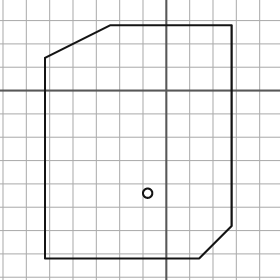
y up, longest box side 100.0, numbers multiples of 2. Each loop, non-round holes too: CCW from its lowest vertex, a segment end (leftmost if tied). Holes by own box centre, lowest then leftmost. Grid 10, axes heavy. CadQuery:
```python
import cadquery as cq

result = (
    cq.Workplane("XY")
    .moveTo(-52.0, -72.0)
    .lineTo(14.0, -72.0)
    .lineTo(28.0, -58.0)
    .lineTo(28.0, 28.0)
    .lineTo(-24.0, 28.0)
    .lineTo(-52.0, 14.0)
    .close()
    .moveTo(-8.0, -44.0)
    .circle(2.0)
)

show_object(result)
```